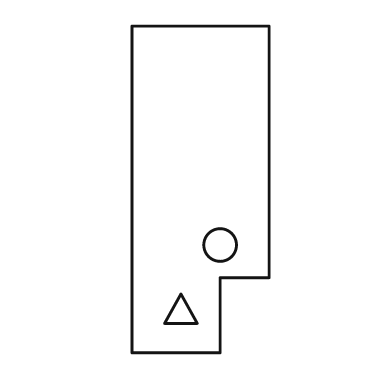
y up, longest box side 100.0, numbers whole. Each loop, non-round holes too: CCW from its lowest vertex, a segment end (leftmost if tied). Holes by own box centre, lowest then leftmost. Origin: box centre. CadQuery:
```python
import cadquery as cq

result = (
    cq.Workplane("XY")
    .moveTo(-21.0, -50.0)
    .lineTo(6.0, -50.0)
    .lineTo(6.0, -27.0)
    .lineTo(21.0, -27.0)
    .lineTo(21.0, 50.0)
    .lineTo(-21.0, 50.0)
    .close()
    .moveTo(-11.0, -41.0)
    .lineTo(-1.0, -41.0)
    .lineTo(-6.0, -32.0)
    .close()
    .moveTo(6.0, -17.0)
    .circle(5.0)
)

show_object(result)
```